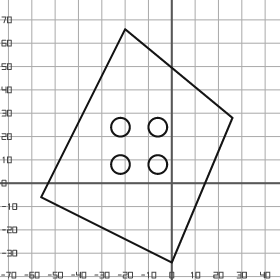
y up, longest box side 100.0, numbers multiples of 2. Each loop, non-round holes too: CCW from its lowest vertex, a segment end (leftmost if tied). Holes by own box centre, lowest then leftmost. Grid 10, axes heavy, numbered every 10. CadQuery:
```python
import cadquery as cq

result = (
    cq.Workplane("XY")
    .moveTo(0.0, -34.0)
    .lineTo(26.0, 28.0)
    .lineTo(-20.0, 66.0)
    .lineTo(-56.0, -6.0)
    .close()
    .moveTo(-22.0, 8.0)
    .circle(4.0)
    .moveTo(-6.0, 8.0)
    .circle(4.0)
    .moveTo(-22.0, 24.0)
    .circle(4.0)
    .moveTo(-6.0, 24.0)
    .circle(4.0)
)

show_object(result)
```